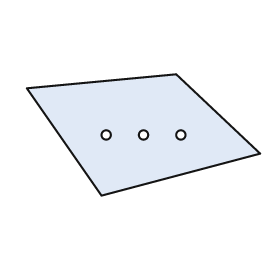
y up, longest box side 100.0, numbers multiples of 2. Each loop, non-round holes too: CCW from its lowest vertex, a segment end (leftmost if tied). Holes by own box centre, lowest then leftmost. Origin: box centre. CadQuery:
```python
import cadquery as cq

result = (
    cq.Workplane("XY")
    .moveTo(-18.0, -26.0)
    .lineTo(50.0, -8.0)
    .lineTo(14.0, 26.0)
    .lineTo(-50.0, 20.0)
    .close()
    .moveTo(-16.0, 0.0)
    .circle(2.0)
    .moveTo(0.0, 0.0)
    .circle(2.0)
    .moveTo(16.0, 0.0)
    .circle(2.0)
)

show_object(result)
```